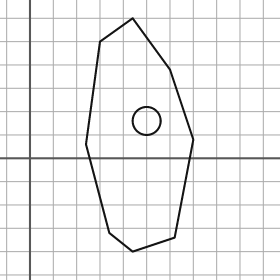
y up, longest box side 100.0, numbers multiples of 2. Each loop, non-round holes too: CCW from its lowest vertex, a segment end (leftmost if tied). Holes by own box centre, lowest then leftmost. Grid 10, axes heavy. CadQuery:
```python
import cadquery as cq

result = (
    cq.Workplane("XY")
    .moveTo(44.0, -40.0)
    .lineTo(62.0, -34.0)
    .lineTo(70.0, 8.0)
    .lineTo(60.0, 38.0)
    .lineTo(44.0, 60.0)
    .lineTo(30.0, 50.0)
    .lineTo(24.0, 6.0)
    .lineTo(34.0, -32.0)
    .close()
    .moveTo(50.0, 16.0)
    .circle(6.0)
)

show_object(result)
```